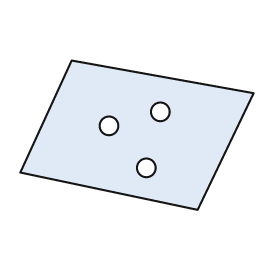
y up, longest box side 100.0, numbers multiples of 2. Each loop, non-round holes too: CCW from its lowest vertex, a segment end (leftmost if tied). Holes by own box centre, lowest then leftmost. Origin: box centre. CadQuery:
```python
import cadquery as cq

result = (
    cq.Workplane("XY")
    .moveTo(26.0, -32.0)
    .lineTo(50.0, 18.0)
    .lineTo(-28.0, 32.0)
    .lineTo(-50.0, -16.0)
    .close()
    .moveTo(4.0, -14.0)
    .circle(4.0)
    .moveTo(-12.0, 4.0)
    .circle(4.0)
    .moveTo(10.0, 10.0)
    .circle(4.0)
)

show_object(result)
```